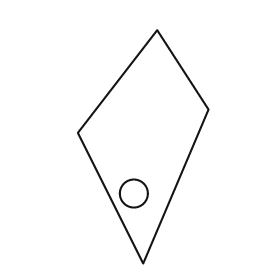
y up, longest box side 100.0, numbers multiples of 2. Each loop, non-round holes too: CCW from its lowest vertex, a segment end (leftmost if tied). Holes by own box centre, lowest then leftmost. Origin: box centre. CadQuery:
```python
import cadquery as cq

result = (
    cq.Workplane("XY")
    .moveTo(0.0, -50.0)
    .lineTo(28.0, 16.0)
    .lineTo(6.0, 50.0)
    .lineTo(-28.0, 6.0)
    .close()
    .moveTo(-4.0, -20.0)
    .circle(6.0)
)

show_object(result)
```